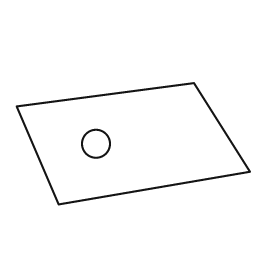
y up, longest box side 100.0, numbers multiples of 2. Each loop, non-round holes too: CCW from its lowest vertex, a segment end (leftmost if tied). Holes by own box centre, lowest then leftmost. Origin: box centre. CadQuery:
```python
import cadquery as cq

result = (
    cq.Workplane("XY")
    .moveTo(-32.0, -26.0)
    .lineTo(50.0, -12.0)
    .lineTo(26.0, 26.0)
    .lineTo(-50.0, 16.0)
    .close()
    .moveTo(-16.0, 0.0)
    .circle(6.0)
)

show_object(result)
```